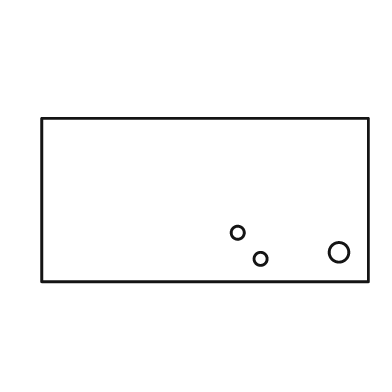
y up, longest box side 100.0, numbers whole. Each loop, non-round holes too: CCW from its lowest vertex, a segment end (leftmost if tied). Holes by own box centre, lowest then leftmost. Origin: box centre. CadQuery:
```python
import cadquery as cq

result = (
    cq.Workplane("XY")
    .moveTo(-50.0, -25.0)
    .lineTo(50.0, -25.0)
    .lineTo(50.0, 25.0)
    .lineTo(-50.0, 25.0)
    .close()
    .moveTo(17.0, -18.0)
    .circle(2.0)
    .moveTo(41.0, -16.0)
    .circle(3.0)
    .moveTo(10.0, -10.0)
    .circle(2.0)
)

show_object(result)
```